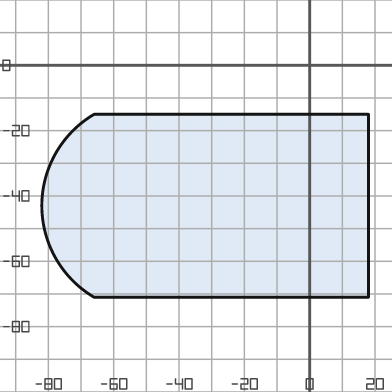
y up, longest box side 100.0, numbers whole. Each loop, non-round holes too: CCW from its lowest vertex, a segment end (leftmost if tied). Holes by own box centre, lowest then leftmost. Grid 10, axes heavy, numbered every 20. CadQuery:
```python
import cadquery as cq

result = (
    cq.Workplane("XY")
    .moveTo(-66.0, -71.0)
    .lineTo(18.0, -71.0)
    .lineTo(18.0, -15.0)
    .lineTo(-66.0, -15.0)
    .threePointArc((-82.0, -43.0), (-66.0, -71.0))
    .close()
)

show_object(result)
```